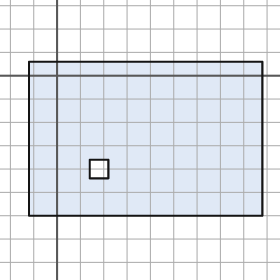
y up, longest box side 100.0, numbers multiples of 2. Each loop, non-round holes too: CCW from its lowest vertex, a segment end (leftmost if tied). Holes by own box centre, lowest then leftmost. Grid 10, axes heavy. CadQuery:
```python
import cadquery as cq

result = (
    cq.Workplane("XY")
    .moveTo(-12.0, -60.0)
    .lineTo(88.0, -60.0)
    .lineTo(88.0, 6.0)
    .lineTo(-12.0, 6.0)
    .close()
    .moveTo(14.0, -44.0)
    .lineTo(22.0, -44.0)
    .lineTo(22.0, -36.0)
    .lineTo(14.0, -36.0)
    .close()
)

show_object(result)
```